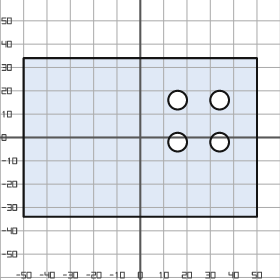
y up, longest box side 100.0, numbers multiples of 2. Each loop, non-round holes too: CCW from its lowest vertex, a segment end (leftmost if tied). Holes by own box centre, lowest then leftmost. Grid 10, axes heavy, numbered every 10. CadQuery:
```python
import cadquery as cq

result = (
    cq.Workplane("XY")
    .moveTo(-50.0, -34.0)
    .lineTo(50.0, -34.0)
    .lineTo(50.0, 34.0)
    .lineTo(-50.0, 34.0)
    .close()
    .moveTo(16.0, -2.0)
    .circle(4.0)
    .moveTo(34.0, -2.0)
    .circle(4.0)
    .moveTo(16.0, 16.0)
    .circle(4.0)
    .moveTo(34.0, 16.0)
    .circle(4.0)
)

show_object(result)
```